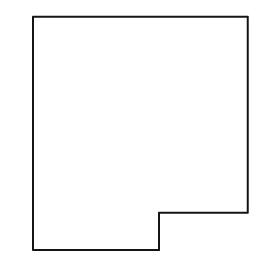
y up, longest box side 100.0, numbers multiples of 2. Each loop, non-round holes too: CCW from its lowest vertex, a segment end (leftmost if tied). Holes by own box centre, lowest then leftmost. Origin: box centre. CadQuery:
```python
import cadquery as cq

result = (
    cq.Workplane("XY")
    .moveTo(-46.0, -50.0)
    .lineTo(8.0, -50.0)
    .lineTo(8.0, -34.0)
    .lineTo(46.0, -34.0)
    .lineTo(46.0, 50.0)
    .lineTo(-46.0, 50.0)
    .close()
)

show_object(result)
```